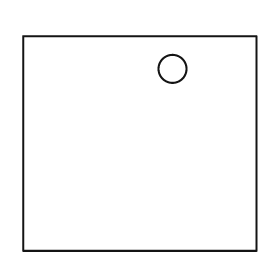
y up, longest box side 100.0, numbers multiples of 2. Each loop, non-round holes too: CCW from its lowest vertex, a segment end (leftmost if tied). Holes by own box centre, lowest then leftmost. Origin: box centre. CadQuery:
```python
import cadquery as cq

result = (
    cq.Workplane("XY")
    .moveTo(-50.0, -46.0)
    .lineTo(50.0, -46.0)
    .lineTo(50.0, 46.0)
    .lineTo(-50.0, 46.0)
    .close()
    .moveTo(14.0, 32.0)
    .circle(6.0)
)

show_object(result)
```